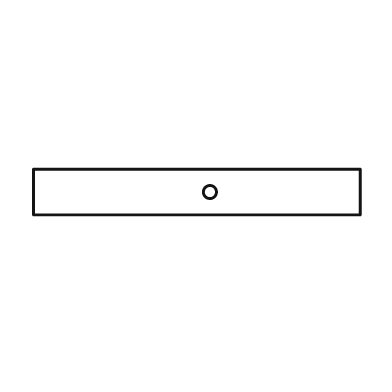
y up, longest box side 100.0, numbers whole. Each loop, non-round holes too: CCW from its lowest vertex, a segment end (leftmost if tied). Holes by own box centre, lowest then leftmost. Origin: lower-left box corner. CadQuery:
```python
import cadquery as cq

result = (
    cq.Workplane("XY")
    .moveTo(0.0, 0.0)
    .lineTo(100.0, 0.0)
    .lineTo(100.0, 14.0)
    .lineTo(0.0, 14.0)
    .close()
    .moveTo(54.0, 7.0)
    .circle(2.0)
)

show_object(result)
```